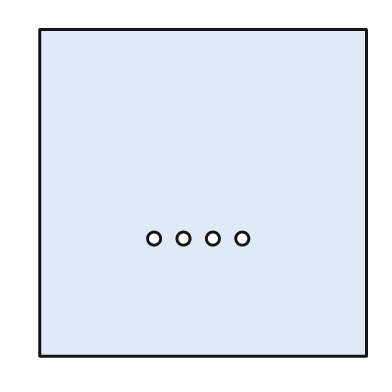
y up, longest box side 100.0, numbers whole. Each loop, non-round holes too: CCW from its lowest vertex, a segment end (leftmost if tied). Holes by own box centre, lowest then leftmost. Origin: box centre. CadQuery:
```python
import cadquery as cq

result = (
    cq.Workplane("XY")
    .moveTo(-50.0, -50.0)
    .lineTo(50.0, -50.0)
    .lineTo(50.0, 50.0)
    .lineTo(-50.0, 50.0)
    .close()
    .moveTo(-15.0, -14.0)
    .circle(2.0)
    .moveTo(-6.0, -14.0)
    .circle(2.0)
    .moveTo(3.0, -14.0)
    .circle(2.0)
    .moveTo(12.0, -14.0)
    .circle(2.0)
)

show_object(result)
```